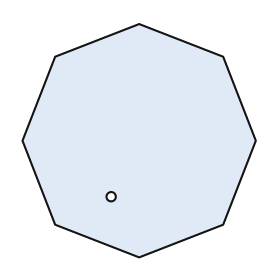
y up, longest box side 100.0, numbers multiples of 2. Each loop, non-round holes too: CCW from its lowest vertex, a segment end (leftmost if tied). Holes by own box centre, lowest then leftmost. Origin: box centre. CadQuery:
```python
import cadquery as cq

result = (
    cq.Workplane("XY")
    .moveTo(0.0, -50.0)
    .lineTo(36.0, -36.0)
    .lineTo(50.0, 0.0)
    .lineTo(36.0, 36.0)
    .lineTo(0.0, 50.0)
    .lineTo(-36.0, 36.0)
    .lineTo(-50.0, 0.0)
    .lineTo(-36.0, -36.0)
    .close()
    .moveTo(-12.0, -24.0)
    .circle(2.0)
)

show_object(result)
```